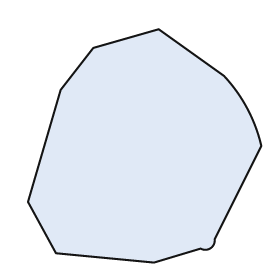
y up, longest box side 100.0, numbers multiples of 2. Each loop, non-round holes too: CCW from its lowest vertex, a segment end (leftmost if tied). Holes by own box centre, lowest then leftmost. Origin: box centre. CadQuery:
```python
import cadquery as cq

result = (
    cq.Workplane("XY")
    .moveTo(4.0, -50.0)
    .lineTo(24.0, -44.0)
    .threePointArc((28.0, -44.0), (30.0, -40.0))
    .lineTo(50.0, 0.0)
    .threePointArc((44.0, 16.0), (34.0, 30.0))
    .lineTo(6.0, 50.0)
    .lineTo(-22.0, 42.0)
    .lineTo(-36.0, 24.0)
    .lineTo(-50.0, -24.0)
    .lineTo(-38.0, -46.0)
    .close()
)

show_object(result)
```